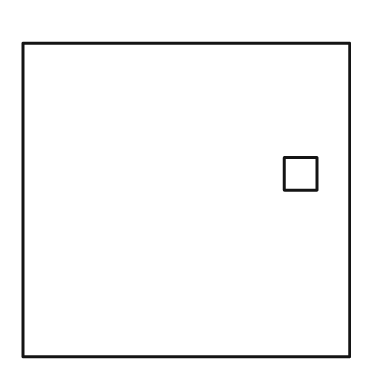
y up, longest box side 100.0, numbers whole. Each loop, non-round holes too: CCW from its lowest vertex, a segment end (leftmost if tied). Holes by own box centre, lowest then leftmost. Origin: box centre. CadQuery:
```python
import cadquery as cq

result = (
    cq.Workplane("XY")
    .moveTo(-50.0, -48.0)
    .lineTo(50.0, -48.0)
    .lineTo(50.0, 48.0)
    .lineTo(-50.0, 48.0)
    .close()
    .moveTo(30.0, 3.0)
    .lineTo(40.0, 3.0)
    .lineTo(40.0, 13.0)
    .lineTo(30.0, 13.0)
    .close()
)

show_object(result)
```